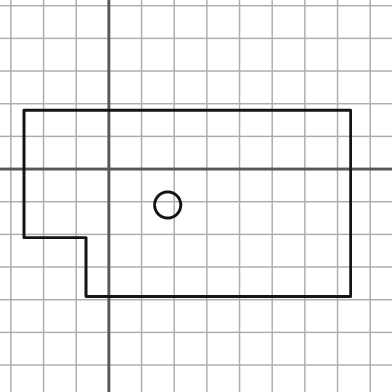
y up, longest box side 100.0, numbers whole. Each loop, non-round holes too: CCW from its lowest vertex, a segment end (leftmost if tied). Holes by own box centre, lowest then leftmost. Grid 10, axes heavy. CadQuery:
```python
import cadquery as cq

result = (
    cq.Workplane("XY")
    .moveTo(-7.0, -39.0)
    .lineTo(74.0, -39.0)
    .lineTo(74.0, 18.0)
    .lineTo(-26.0, 18.0)
    .lineTo(-26.0, -21.0)
    .lineTo(-7.0, -21.0)
    .close()
    .moveTo(18.0, -11.0)
    .circle(4.0)
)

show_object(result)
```